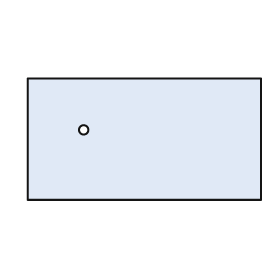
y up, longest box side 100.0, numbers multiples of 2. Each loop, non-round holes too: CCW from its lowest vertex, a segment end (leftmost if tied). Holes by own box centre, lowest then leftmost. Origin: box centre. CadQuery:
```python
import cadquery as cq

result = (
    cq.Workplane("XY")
    .moveTo(-50.0, -26.0)
    .lineTo(50.0, -26.0)
    .lineTo(50.0, 26.0)
    .lineTo(-50.0, 26.0)
    .close()
    .moveTo(-26.0, 4.0)
    .circle(2.0)
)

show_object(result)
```